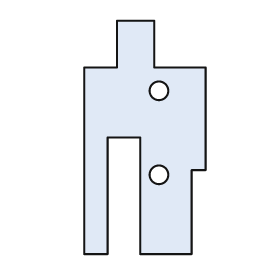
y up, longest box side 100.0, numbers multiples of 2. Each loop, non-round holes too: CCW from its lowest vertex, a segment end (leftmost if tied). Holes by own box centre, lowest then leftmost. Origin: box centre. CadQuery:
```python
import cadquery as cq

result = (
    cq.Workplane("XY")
    .moveTo(-26.0, -50.0)
    .lineTo(-16.0, -50.0)
    .lineTo(-16.0, 0.0)
    .lineTo(-2.0, 0.0)
    .lineTo(-2.0, -50.0)
    .lineTo(20.0, -50.0)
    .lineTo(20.0, -14.0)
    .lineTo(26.0, -14.0)
    .lineTo(26.0, 30.0)
    .lineTo(4.0, 30.0)
    .lineTo(4.0, 50.0)
    .lineTo(-12.0, 50.0)
    .lineTo(-12.0, 30.0)
    .lineTo(-26.0, 30.0)
    .close()
    .moveTo(6.0, -16.0)
    .circle(4.0)
    .moveTo(6.0, 20.0)
    .circle(4.0)
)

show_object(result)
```